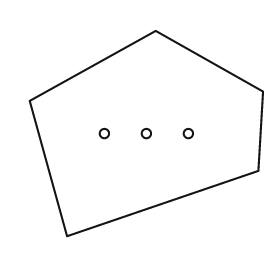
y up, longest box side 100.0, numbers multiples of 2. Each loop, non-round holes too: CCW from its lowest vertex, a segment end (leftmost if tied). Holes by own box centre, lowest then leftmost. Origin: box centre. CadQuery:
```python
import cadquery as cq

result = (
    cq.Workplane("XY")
    .moveTo(-34.0, -44.0)
    .lineTo(48.0, -16.0)
    .lineTo(50.0, 18.0)
    .lineTo(4.0, 44.0)
    .lineTo(-50.0, 14.0)
    .close()
    .moveTo(-18.0, 0.0)
    .circle(2.0)
    .moveTo(0.0, 0.0)
    .circle(2.0)
    .moveTo(18.0, 0.0)
    .circle(2.0)
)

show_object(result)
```